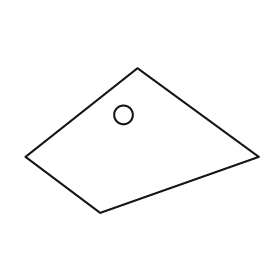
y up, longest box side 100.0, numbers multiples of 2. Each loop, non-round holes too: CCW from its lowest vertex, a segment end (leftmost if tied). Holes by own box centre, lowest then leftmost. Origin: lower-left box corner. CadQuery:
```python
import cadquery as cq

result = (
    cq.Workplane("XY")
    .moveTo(32.0, 0.0)
    .lineTo(100.0, 24.0)
    .lineTo(48.0, 62.0)
    .lineTo(0.0, 24.0)
    .close()
    .moveTo(42.0, 42.0)
    .circle(4.0)
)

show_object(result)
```